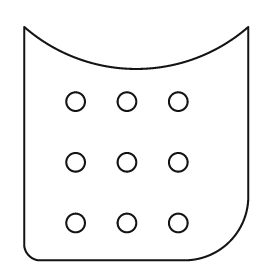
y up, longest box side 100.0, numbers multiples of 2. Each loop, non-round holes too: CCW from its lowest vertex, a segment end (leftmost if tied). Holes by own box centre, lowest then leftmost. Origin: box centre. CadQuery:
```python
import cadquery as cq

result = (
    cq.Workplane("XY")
    .moveTo(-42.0, -50.0)
    .lineTo(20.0, -50.0)
    .threePointArc((40.0, -42.0), (48.0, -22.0))
    .lineTo(48.0, 50.0)
    .threePointArc((0.0, 32.0), (-48.0, 50.0))
    .lineTo(-48.0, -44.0)
    .threePointArc((-46.0, -48.0), (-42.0, -50.0))
    .close()
    .moveTo(-26.0, -34.0)
    .circle(4.0)
    .moveTo(-4.0, -34.0)
    .circle(4.0)
    .moveTo(18.0, -34.0)
    .circle(4.0)
    .moveTo(-26.0, -8.0)
    .circle(4.0)
    .moveTo(-4.0, -8.0)
    .circle(4.0)
    .moveTo(18.0, -8.0)
    .circle(4.0)
    .moveTo(-26.0, 18.0)
    .circle(4.0)
    .moveTo(-4.0, 18.0)
    .circle(4.0)
    .moveTo(18.0, 18.0)
    .circle(4.0)
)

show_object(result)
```